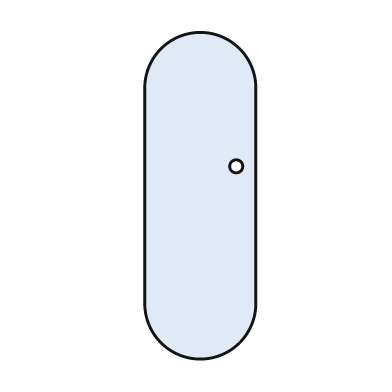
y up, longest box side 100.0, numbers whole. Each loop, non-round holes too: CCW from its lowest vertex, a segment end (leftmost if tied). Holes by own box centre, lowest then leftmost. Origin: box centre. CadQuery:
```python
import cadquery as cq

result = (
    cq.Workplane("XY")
    .moveTo(-17.0, -33.0)
    .threePointArc((0.0, -50.0), (17.0, -33.0))
    .lineTo(17.0, 33.0)
    .threePointArc((0.0, 50.0), (-17.0, 33.0))
    .close()
    .moveTo(11.0, 9.0)
    .circle(2.0)
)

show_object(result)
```